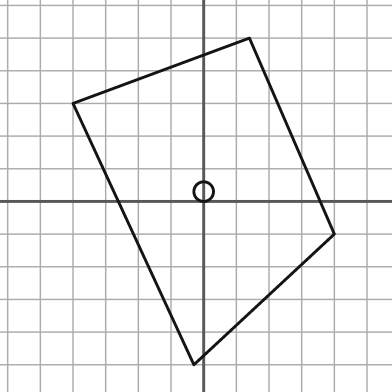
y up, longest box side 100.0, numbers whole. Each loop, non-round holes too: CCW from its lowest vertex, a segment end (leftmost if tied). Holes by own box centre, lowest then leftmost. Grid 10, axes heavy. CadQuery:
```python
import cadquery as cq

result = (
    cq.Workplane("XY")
    .moveTo(-3.0, -50.0)
    .lineTo(40.0, -10.0)
    .lineTo(14.0, 50.0)
    .lineTo(-40.0, 30.0)
    .close()
    .moveTo(0.0, 3.0)
    .circle(3.0)
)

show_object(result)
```